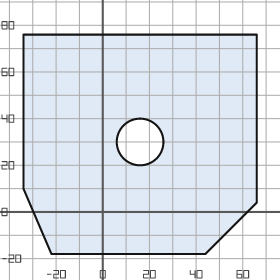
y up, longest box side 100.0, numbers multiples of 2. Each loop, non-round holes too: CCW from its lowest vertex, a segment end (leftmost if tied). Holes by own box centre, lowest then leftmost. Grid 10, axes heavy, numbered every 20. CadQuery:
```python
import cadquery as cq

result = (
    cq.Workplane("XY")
    .moveTo(-22.0, -18.0)
    .lineTo(44.0, -18.0)
    .lineTo(66.0, 4.0)
    .lineTo(66.0, 76.0)
    .lineTo(-34.0, 76.0)
    .lineTo(-34.0, 10.0)
    .close()
    .moveTo(16.0, 30.0)
    .circle(10.0)
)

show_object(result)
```